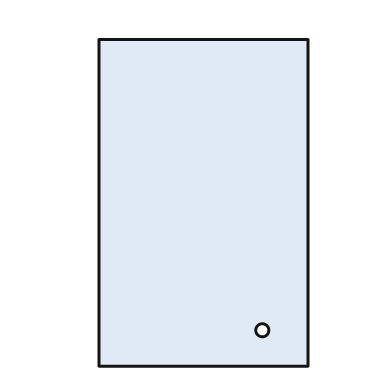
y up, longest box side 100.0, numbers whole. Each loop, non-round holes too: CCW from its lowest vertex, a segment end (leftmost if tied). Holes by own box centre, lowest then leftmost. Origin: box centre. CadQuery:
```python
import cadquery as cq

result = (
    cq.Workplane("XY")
    .moveTo(-32.0, -50.0)
    .lineTo(32.0, -50.0)
    .lineTo(32.0, 50.0)
    .lineTo(-32.0, 50.0)
    .close()
    .moveTo(18.0, -39.0)
    .circle(2.0)
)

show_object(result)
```